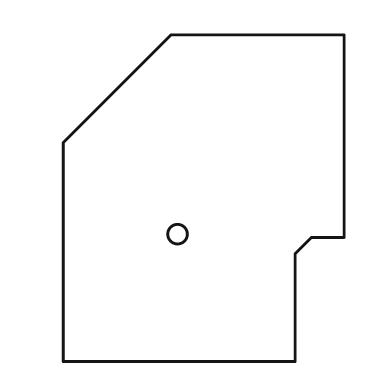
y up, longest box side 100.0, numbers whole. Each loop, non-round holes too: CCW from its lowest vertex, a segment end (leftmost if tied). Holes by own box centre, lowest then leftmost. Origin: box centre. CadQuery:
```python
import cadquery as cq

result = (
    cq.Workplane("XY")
    .moveTo(-43.0, -50.0)
    .lineTo(28.0, -50.0)
    .lineTo(28.0, -17.0)
    .lineTo(33.0, -12.0)
    .lineTo(43.0, -12.0)
    .lineTo(43.0, 50.0)
    .lineTo(-10.0, 50.0)
    .lineTo(-43.0, 17.0)
    .close()
    .moveTo(-8.0, -11.0)
    .circle(3.0)
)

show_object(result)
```